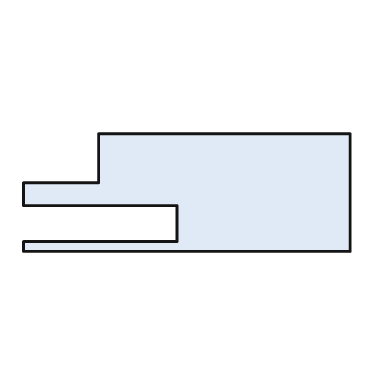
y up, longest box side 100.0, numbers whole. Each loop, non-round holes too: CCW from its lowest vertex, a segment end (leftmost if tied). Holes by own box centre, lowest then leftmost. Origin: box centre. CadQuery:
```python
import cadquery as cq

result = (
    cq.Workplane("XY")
    .moveTo(-50.0, -18.0)
    .lineTo(50.0, -18.0)
    .lineTo(50.0, 18.0)
    .lineTo(-27.0, 18.0)
    .lineTo(-27.0, 3.0)
    .lineTo(-50.0, 3.0)
    .lineTo(-50.0, -4.0)
    .lineTo(-3.0, -4.0)
    .lineTo(-3.0, -15.0)
    .lineTo(-50.0, -15.0)
    .close()
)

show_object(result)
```